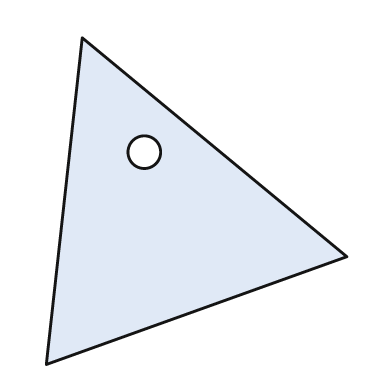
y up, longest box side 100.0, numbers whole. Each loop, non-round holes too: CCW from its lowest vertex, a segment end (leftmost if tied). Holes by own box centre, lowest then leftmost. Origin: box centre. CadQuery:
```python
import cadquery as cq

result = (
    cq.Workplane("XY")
    .moveTo(-46.0, -50.0)
    .lineTo(46.0, -17.0)
    .lineTo(-35.0, 50.0)
    .close()
    .moveTo(-16.0, 15.0)
    .circle(5.0)
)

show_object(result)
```